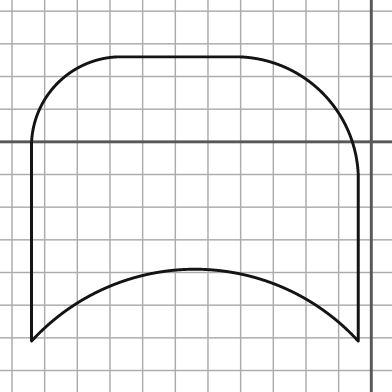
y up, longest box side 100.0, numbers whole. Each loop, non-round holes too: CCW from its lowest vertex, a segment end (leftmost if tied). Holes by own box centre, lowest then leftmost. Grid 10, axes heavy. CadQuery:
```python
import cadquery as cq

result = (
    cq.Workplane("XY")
    .moveTo(-104.0, -61.0)
    .threePointArc((-54.0, -39.0), (-4.0, -61.0))
    .lineTo(-4.0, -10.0)
    .threePointArc((-15.0, 15.0), (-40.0, 26.0))
    .lineTo(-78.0, 26.0)
    .threePointArc((-96.0, 18.0), (-104.0, 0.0))
    .close()
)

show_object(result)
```